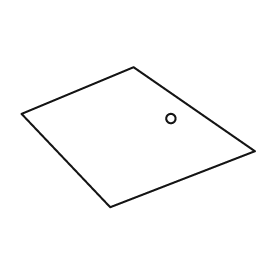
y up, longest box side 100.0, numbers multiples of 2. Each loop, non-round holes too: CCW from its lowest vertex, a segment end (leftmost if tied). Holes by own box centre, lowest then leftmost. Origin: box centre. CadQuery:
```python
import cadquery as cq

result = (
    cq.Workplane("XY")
    .moveTo(-12.0, -30.0)
    .lineTo(50.0, -6.0)
    .lineTo(-2.0, 30.0)
    .lineTo(-50.0, 10.0)
    .close()
    .moveTo(14.0, 8.0)
    .circle(2.0)
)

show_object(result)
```